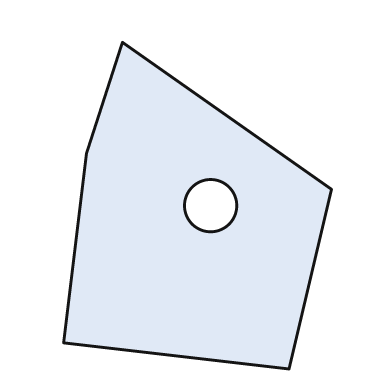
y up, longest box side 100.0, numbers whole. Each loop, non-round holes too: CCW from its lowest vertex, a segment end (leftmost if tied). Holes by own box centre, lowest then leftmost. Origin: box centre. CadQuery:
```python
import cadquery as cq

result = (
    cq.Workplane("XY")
    .moveTo(28.0, -50.0)
    .lineTo(41.0, 5.0)
    .lineTo(-23.0, 50.0)
    .lineTo(-34.0, 16.0)
    .lineTo(-41.0, -42.0)
    .close()
    .moveTo(4.0, 0.0)
    .circle(8.0)
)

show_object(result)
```